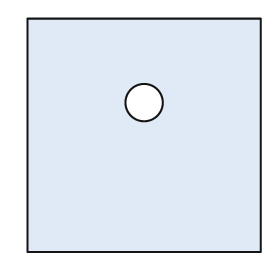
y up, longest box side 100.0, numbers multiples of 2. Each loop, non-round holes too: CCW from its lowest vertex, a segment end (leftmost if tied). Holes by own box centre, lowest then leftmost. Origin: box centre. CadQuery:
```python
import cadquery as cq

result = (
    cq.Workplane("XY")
    .moveTo(-50.0, -50.0)
    .lineTo(50.0, -50.0)
    .lineTo(50.0, 50.0)
    .lineTo(-50.0, 50.0)
    .close()
    .moveTo(0.0, 14.0)
    .circle(8.0)
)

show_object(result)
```